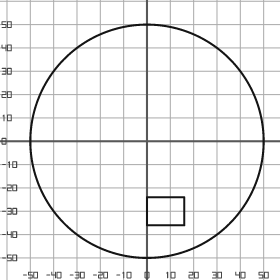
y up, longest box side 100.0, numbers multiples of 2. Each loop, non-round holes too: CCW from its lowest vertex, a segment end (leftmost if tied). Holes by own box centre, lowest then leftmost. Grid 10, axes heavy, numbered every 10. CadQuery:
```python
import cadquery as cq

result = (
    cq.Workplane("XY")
    .moveTo(0.0, 0.0)
    .circle(50.0)
    .moveTo(0.0, -36.0)
    .lineTo(16.0, -36.0)
    .lineTo(16.0, -24.0)
    .lineTo(0.0, -24.0)
    .close()
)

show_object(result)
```